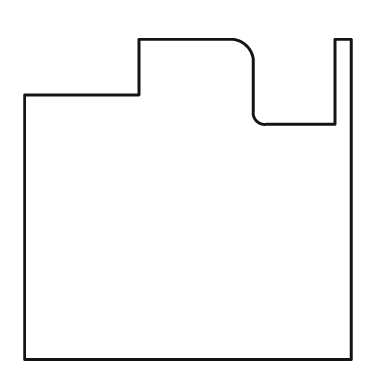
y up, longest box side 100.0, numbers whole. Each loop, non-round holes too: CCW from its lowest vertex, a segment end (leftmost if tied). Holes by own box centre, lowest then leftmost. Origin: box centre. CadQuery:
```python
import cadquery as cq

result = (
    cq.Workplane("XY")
    .moveTo(-50.0, -49.0)
    .lineTo(50.0, -49.0)
    .lineTo(50.0, 49.0)
    .lineTo(45.0, 49.0)
    .lineTo(45.0, 23.0)
    .lineTo(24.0, 23.0)
    .threePointArc((21.0, 24.0), (20.0, 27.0))
    .lineTo(20.0, 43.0)
    .threePointArc((18.0, 47.0), (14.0, 49.0))
    .lineTo(-15.0, 49.0)
    .lineTo(-15.0, 32.0)
    .lineTo(-50.0, 32.0)
    .close()
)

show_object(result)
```